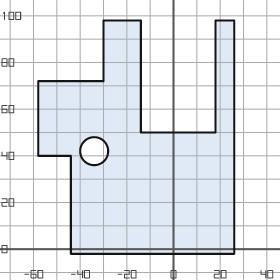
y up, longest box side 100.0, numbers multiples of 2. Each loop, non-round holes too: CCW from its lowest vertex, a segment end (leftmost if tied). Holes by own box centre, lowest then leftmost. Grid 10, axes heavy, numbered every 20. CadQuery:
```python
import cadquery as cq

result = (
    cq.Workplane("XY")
    .moveTo(-44.0, -2.0)
    .lineTo(26.0, -2.0)
    .lineTo(26.0, 98.0)
    .lineTo(18.0, 98.0)
    .lineTo(18.0, 50.0)
    .lineTo(-14.0, 50.0)
    .lineTo(-14.0, 98.0)
    .lineTo(-30.0, 98.0)
    .lineTo(-30.0, 72.0)
    .lineTo(-58.0, 72.0)
    .lineTo(-58.0, 40.0)
    .lineTo(-44.0, 40.0)
    .close()
    .moveTo(-34.0, 42.0)
    .circle(6.0)
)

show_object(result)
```